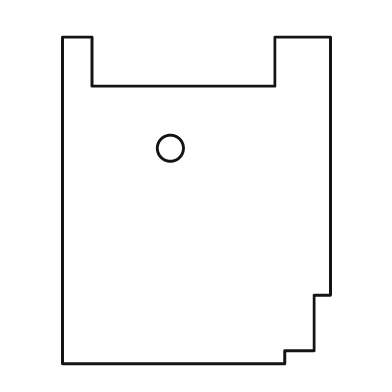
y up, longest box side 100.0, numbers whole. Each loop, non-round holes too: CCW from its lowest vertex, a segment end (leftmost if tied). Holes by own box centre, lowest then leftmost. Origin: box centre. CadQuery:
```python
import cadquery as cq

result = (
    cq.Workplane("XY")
    .moveTo(-41.0, -50.0)
    .lineTo(27.0, -50.0)
    .lineTo(27.0, -46.0)
    .lineTo(36.0, -46.0)
    .lineTo(36.0, -29.0)
    .lineTo(41.0, -29.0)
    .lineTo(41.0, 50.0)
    .lineTo(24.0, 50.0)
    .lineTo(24.0, 35.0)
    .lineTo(-32.0, 35.0)
    .lineTo(-32.0, 50.0)
    .lineTo(-41.0, 50.0)
    .close()
    .moveTo(-8.0, 16.0)
    .circle(4.0)
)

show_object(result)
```